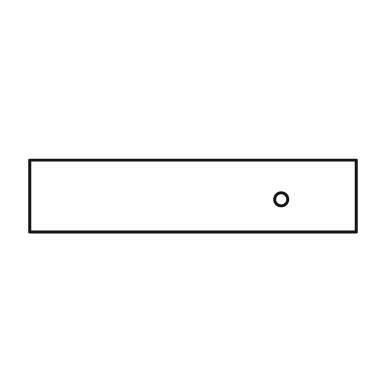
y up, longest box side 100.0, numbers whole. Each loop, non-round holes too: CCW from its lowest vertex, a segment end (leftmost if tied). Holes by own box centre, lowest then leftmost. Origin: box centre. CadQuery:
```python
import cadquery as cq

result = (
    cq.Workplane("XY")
    .moveTo(-50.0, -11.0)
    .lineTo(50.0, -11.0)
    .lineTo(50.0, 11.0)
    .lineTo(-50.0, 11.0)
    .close()
    .moveTo(27.0, -1.0)
    .circle(2.0)
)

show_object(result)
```